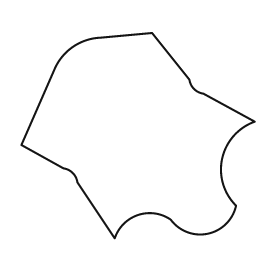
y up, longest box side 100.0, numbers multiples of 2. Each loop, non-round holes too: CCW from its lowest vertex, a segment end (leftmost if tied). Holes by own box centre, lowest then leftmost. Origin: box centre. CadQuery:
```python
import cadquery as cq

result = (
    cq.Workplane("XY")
    .moveTo(-10.0, -44.0)
    .threePointArc((0.0, -34.0), (14.0, -36.0))
    .threePointArc((30.0, -42.0), (42.0, -30.0))
    .threePointArc((36.0, -10.0), (50.0, 6.0))
    .lineTo(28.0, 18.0)
    .threePointArc((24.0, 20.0), (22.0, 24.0))
    .lineTo(6.0, 44.0)
    .lineTo(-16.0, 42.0)
    .threePointArc((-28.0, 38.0), (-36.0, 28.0))
    .lineTo(-50.0, -4.0)
    .lineTo(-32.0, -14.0)
    .threePointArc((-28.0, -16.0), (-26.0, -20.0))
    .close()
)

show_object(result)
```